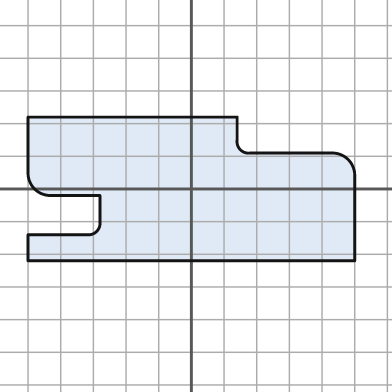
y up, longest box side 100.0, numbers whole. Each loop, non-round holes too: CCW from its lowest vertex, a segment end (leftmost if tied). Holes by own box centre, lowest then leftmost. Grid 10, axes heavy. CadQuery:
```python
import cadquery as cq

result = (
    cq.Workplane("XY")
    .moveTo(-50.0, -22.0)
    .lineTo(50.0, -22.0)
    .lineTo(50.0, 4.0)
    .threePointArc((48.0, 9.0), (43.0, 11.0))
    .lineTo(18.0, 11.0)
    .threePointArc((15.0, 12.0), (14.0, 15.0))
    .lineTo(14.0, 22.0)
    .lineTo(-50.0, 22.0)
    .lineTo(-50.0, 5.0)
    .threePointArc((-48.0, 0.0), (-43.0, -2.0))
    .lineTo(-28.0, -2.0)
    .lineTo(-28.0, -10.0)
    .threePointArc((-29.0, -13.0), (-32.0, -14.0))
    .lineTo(-50.0, -14.0)
    .close()
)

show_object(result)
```